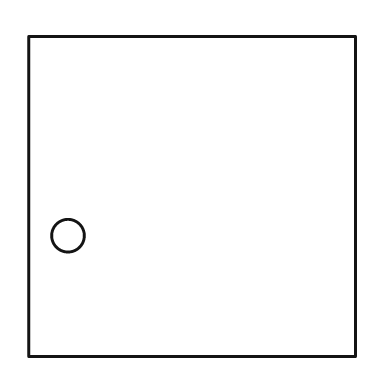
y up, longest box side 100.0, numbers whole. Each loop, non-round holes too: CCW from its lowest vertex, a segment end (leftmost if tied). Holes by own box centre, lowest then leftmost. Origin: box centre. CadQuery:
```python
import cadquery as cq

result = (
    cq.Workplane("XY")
    .moveTo(-50.0, -49.0)
    .lineTo(50.0, -49.0)
    .lineTo(50.0, 49.0)
    .lineTo(-50.0, 49.0)
    .close()
    .moveTo(-38.0, -12.0)
    .circle(5.0)
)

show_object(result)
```